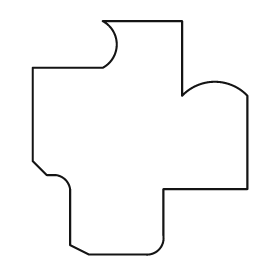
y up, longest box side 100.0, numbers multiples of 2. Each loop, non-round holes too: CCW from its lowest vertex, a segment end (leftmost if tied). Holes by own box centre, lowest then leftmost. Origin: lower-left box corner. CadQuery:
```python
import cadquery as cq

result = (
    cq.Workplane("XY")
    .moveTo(24.0, 0.0)
    .lineTo(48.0, 0.0)
    .threePointArc((54.0, 2.0), (56.0, 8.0))
    .lineTo(56.0, 28.0)
    .lineTo(92.0, 28.0)
    .lineTo(92.0, 68.0)
    .threePointArc((78.0, 74.0), (64.0, 68.0))
    .lineTo(64.0, 100.0)
    .lineTo(30.0, 100.0)
    .threePointArc((36.0, 90.0), (30.0, 80.0))
    .lineTo(0.0, 80.0)
    .lineTo(0.0, 40.0)
    .lineTo(6.0, 34.0)
    .lineTo(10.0, 34.0)
    .threePointArc((14.0, 32.0), (16.0, 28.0))
    .lineTo(16.0, 4.0)
    .close()
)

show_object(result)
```